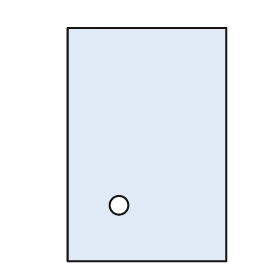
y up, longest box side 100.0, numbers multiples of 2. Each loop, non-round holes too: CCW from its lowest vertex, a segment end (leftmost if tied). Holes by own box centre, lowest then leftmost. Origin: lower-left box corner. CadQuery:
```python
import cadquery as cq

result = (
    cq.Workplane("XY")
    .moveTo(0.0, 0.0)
    .lineTo(68.0, 0.0)
    .lineTo(68.0, 100.0)
    .lineTo(0.0, 100.0)
    .close()
    .moveTo(22.0, 24.0)
    .circle(4.0)
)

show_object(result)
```